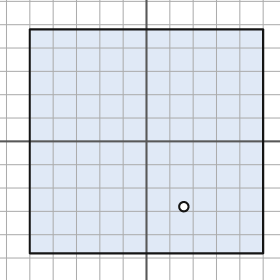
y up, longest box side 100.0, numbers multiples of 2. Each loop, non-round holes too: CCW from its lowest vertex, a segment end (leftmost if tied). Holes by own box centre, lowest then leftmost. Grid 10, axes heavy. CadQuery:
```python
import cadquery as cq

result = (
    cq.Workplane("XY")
    .moveTo(-50.0, -48.0)
    .lineTo(50.0, -48.0)
    .lineTo(50.0, 48.0)
    .lineTo(-50.0, 48.0)
    .close()
    .moveTo(16.0, -28.0)
    .circle(2.0)
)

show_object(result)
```